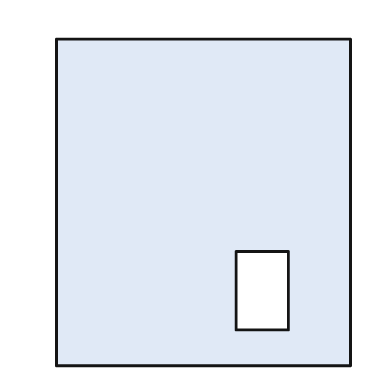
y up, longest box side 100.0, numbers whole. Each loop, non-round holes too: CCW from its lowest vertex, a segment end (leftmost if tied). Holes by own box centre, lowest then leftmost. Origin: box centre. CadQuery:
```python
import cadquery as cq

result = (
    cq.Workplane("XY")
    .moveTo(-45.0, -50.0)
    .lineTo(45.0, -50.0)
    .lineTo(45.0, 50.0)
    .lineTo(-45.0, 50.0)
    .close()
    .moveTo(10.0, -39.0)
    .lineTo(26.0, -39.0)
    .lineTo(26.0, -15.0)
    .lineTo(10.0, -15.0)
    .close()
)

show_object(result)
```